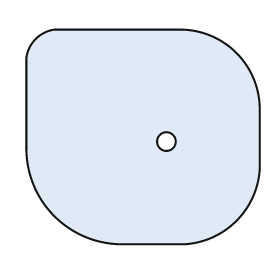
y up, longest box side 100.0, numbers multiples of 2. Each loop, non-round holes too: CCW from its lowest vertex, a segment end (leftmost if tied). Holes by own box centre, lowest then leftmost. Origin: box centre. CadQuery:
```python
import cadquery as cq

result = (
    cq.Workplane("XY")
    .moveTo(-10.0, -46.0)
    .lineTo(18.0, -46.0)
    .threePointArc((40.0, -36.0), (50.0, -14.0))
    .lineTo(50.0, 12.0)
    .threePointArc((40.0, 36.0), (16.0, 46.0))
    .lineTo(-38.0, 46.0)
    .threePointArc((-46.0, 42.0), (-50.0, 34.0))
    .lineTo(-50.0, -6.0)
    .threePointArc((-38.0, -34.0), (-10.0, -46.0))
    .close()
    .moveTo(10.0, -2.0)
    .circle(4.0)
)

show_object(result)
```